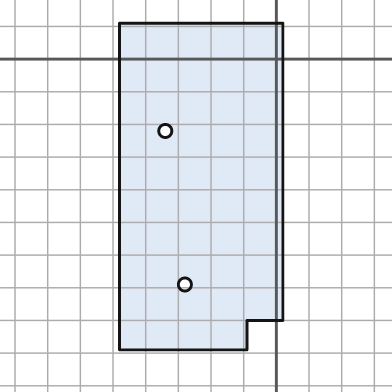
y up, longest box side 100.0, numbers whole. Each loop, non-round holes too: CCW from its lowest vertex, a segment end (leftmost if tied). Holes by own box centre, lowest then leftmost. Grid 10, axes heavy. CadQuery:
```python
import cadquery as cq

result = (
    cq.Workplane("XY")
    .moveTo(-48.0, -89.0)
    .lineTo(-9.0, -89.0)
    .lineTo(-9.0, -80.0)
    .lineTo(2.0, -80.0)
    .lineTo(2.0, 11.0)
    .lineTo(-48.0, 11.0)
    .close()
    .moveTo(-28.0, -69.0)
    .circle(2.0)
    .moveTo(-34.0, -22.0)
    .circle(2.0)
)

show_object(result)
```